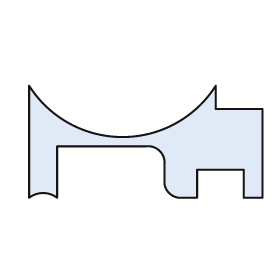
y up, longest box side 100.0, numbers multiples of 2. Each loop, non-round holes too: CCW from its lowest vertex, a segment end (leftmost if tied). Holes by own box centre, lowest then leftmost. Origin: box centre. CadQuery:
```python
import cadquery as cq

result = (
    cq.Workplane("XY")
    .moveTo(-50.0, -24.0)
    .threePointArc((-44.0, -22.0), (-38.0, -24.0))
    .lineTo(-38.0, -2.0)
    .lineTo(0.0, -2.0)
    .threePointArc((6.0, -4.0), (8.0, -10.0))
    .lineTo(8.0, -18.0)
    .threePointArc((10.0, -22.0), (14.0, -24.0))
    .lineTo(22.0, -24.0)
    .lineTo(22.0, -12.0)
    .lineTo(42.0, -12.0)
    .lineTo(42.0, -24.0)
    .lineTo(50.0, -24.0)
    .lineTo(50.0, 14.0)
    .lineTo(30.0, 14.0)
    .lineTo(30.0, 24.0)
    .threePointArc((-10.0, 2.0), (-50.0, 24.0))
    .close()
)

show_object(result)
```